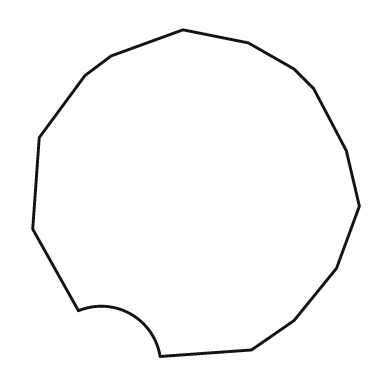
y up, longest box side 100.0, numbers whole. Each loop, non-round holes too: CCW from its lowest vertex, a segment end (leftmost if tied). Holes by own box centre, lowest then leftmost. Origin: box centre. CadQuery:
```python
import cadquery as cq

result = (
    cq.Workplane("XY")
    .moveTo(-11.0, -50.0)
    .lineTo(17.0, -48.0)
    .lineTo(30.0, -39.0)
    .lineTo(43.0, -23.0)
    .lineTo(50.0, -4.0)
    .lineTo(46.0, 13.0)
    .lineTo(36.0, 32.0)
    .lineTo(30.0, 38.0)
    .lineTo(16.0, 46.0)
    .lineTo(-4.0, 50.0)
    .lineTo(-26.0, 42.0)
    .lineTo(-34.0, 36.0)
    .lineTo(-48.0, 17.0)
    .lineTo(-50.0, -11.0)
    .lineTo(-36.0, -36.0)
    .threePointArc((-20.0, -37.0), (-11.0, -50.0))
    .close()
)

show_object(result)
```